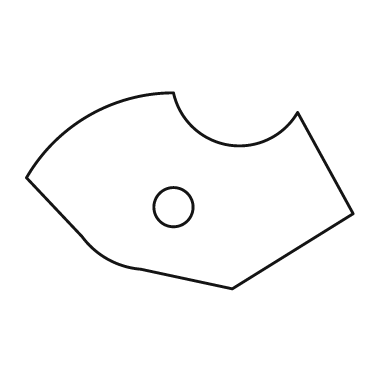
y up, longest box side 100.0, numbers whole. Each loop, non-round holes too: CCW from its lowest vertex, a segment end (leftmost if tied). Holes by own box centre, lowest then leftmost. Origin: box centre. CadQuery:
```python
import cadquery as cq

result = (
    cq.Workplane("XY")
    .moveTo(13.0, -30.0)
    .lineTo(50.0, -7.0)
    .lineTo(33.0, 24.0)
    .threePointArc((12.0, 14.0), (-5.0, 30.0))
    .threePointArc((-31.0, 23.0), (-50.0, 4.0))
    .lineTo(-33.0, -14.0)
    .threePointArc((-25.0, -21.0), (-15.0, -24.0))
    .close()
    .moveTo(-5.0, -5.0)
    .circle(6.0)
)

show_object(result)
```